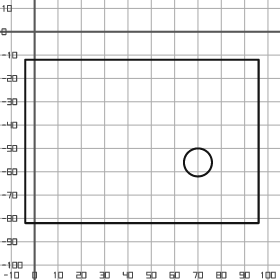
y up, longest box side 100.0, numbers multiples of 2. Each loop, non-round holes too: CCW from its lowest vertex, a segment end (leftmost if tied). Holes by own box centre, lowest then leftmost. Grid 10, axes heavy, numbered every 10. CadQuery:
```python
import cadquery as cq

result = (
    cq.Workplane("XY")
    .moveTo(-4.0, -82.0)
    .lineTo(96.0, -82.0)
    .lineTo(96.0, -12.0)
    .lineTo(-4.0, -12.0)
    .close()
    .moveTo(70.0, -56.0)
    .circle(6.0)
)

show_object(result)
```